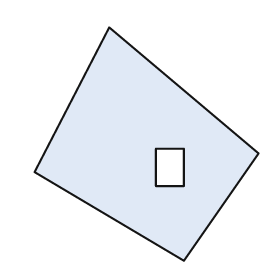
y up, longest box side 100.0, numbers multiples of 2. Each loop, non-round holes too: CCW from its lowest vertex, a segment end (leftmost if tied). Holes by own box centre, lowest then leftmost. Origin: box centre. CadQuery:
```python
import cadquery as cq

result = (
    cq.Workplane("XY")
    .moveTo(16.0, -50.0)
    .lineTo(48.0, -4.0)
    .lineTo(-16.0, 50.0)
    .lineTo(-48.0, -12.0)
    .close()
    .moveTo(4.0, -18.0)
    .lineTo(16.0, -18.0)
    .lineTo(16.0, -2.0)
    .lineTo(4.0, -2.0)
    .close()
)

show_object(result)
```